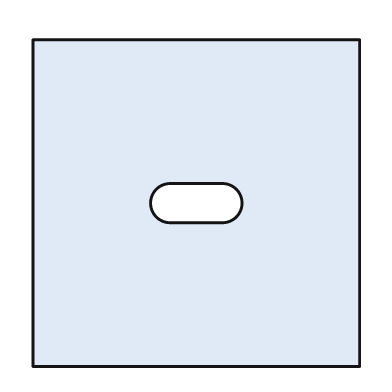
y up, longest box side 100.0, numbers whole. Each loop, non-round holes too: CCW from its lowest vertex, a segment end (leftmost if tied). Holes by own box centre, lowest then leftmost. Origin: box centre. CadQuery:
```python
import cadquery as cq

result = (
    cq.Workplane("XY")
    .moveTo(-50.0, -50.0)
    .lineTo(50.0, -50.0)
    .lineTo(50.0, 50.0)
    .lineTo(-50.0, 50.0)
    .close()
    .moveTo(-8.0, -6.0)
    .lineTo(8.0, -6.0)
    .threePointArc((14.0, 0.0), (8.0, 6.0))
    .lineTo(-8.0, 6.0)
    .threePointArc((-14.0, 0.0), (-8.0, -6.0))
    .close()
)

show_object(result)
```